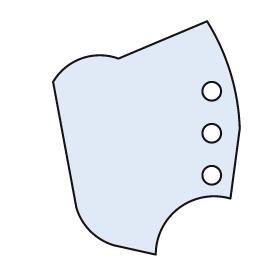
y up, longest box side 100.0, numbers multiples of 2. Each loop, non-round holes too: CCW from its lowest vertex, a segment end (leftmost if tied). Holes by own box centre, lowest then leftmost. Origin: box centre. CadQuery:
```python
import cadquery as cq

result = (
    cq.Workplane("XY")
    .moveTo(4.0, -50.0)
    .threePointArc((14.0, -30.0), (36.0, -26.0))
    .lineTo(40.0, 4.0)
    .threePointArc((36.0, 28.0), (26.0, 50.0))
    .lineTo(-12.0, 34.0)
    .threePointArc((-28.0, 34.0), (-40.0, 24.0))
    .lineTo(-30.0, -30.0)
    .threePointArc((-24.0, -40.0), (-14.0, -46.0))
    .close()
    .moveTo(28.0, -16.0)
    .circle(4.0)
    .moveTo(28.0, 2.0)
    .circle(4.0)
    .moveTo(28.0, 20.0)
    .circle(4.0)
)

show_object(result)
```